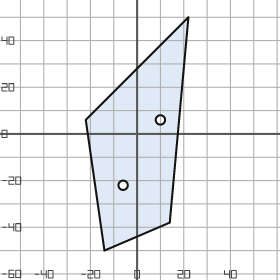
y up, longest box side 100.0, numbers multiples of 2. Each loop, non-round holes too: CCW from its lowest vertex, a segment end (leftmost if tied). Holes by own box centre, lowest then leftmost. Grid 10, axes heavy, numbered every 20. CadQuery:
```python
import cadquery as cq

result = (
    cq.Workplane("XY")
    .moveTo(-14.0, -50.0)
    .lineTo(14.0, -38.0)
    .lineTo(22.0, 50.0)
    .lineTo(-22.0, 6.0)
    .close()
    .moveTo(-6.0, -22.0)
    .circle(2.0)
    .moveTo(10.0, 6.0)
    .circle(2.0)
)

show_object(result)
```